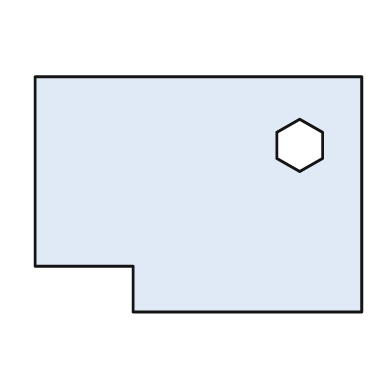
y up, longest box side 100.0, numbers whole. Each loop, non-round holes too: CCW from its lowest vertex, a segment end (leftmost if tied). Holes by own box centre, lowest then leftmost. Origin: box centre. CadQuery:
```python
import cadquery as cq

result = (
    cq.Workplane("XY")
    .moveTo(-20.0, -36.0)
    .lineTo(50.0, -36.0)
    .lineTo(50.0, 36.0)
    .lineTo(-50.0, 36.0)
    .lineTo(-50.0, -22.0)
    .lineTo(-20.0, -22.0)
    .close()
    .moveTo(31.0, 7.0)
    .lineTo(38.0, 11.0)
    .lineTo(38.0, 19.0)
    .lineTo(31.0, 23.0)
    .lineTo(24.0, 19.0)
    .lineTo(24.0, 11.0)
    .close()
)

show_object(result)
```